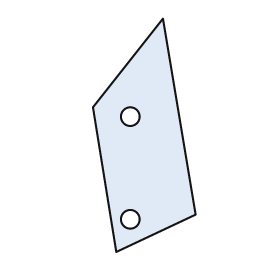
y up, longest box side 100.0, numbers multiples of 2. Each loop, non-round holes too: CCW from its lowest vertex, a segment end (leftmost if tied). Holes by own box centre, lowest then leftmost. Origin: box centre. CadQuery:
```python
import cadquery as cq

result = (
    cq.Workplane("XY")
    .moveTo(-12.0, -50.0)
    .lineTo(22.0, -34.0)
    .lineTo(8.0, 50.0)
    .lineTo(-22.0, 12.0)
    .close()
    .moveTo(-6.0, -36.0)
    .circle(4.0)
    .moveTo(-6.0, 8.0)
    .circle(4.0)
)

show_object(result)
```